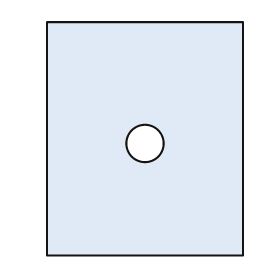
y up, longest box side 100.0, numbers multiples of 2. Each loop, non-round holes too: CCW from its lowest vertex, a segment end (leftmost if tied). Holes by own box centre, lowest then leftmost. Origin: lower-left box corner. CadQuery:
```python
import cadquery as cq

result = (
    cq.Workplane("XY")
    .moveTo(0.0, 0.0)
    .lineTo(84.0, 0.0)
    .lineTo(84.0, 100.0)
    .lineTo(0.0, 100.0)
    .close()
    .moveTo(42.0, 48.0)
    .circle(8.0)
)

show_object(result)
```